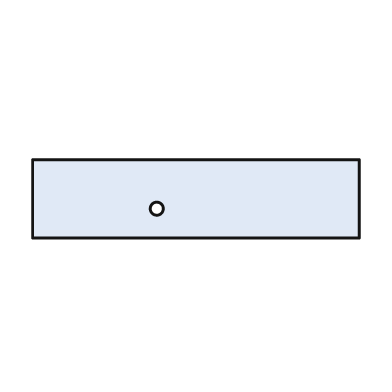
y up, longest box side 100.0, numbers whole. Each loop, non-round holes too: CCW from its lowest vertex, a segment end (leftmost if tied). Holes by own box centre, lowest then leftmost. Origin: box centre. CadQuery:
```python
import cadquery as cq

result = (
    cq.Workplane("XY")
    .moveTo(-50.0, -12.0)
    .lineTo(50.0, -12.0)
    .lineTo(50.0, 12.0)
    .lineTo(-50.0, 12.0)
    .close()
    .moveTo(-12.0, -3.0)
    .circle(2.0)
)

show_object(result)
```